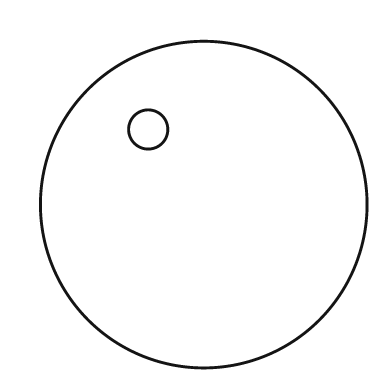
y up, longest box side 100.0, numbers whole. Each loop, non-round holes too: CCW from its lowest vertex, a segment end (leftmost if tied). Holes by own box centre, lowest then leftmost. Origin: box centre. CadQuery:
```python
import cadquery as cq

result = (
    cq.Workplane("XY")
    .moveTo(0.0, 0.0)
    .circle(50.0)
    .moveTo(-17.0, 23.0)
    .circle(6.0)
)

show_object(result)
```